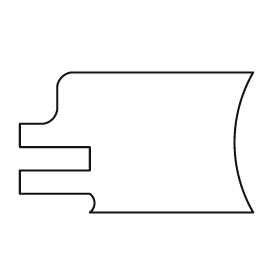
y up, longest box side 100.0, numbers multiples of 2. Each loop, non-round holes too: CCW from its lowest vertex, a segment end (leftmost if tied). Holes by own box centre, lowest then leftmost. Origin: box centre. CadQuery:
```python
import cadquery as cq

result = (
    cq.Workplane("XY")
    .moveTo(-20.0, -30.0)
    .lineTo(50.0, -30.0)
    .threePointArc((42.0, 0.0), (50.0, 30.0))
    .lineTo(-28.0, 30.0)
    .threePointArc((-32.0, 28.0), (-34.0, 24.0))
    .lineTo(-34.0, 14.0)
    .threePointArc((-36.0, 10.0), (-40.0, 8.0))
    .lineTo(-50.0, 8.0)
    .lineTo(-50.0, -2.0)
    .lineTo(-20.0, -2.0)
    .lineTo(-20.0, -12.0)
    .lineTo(-50.0, -12.0)
    .lineTo(-50.0, -22.0)
    .lineTo(-20.0, -22.0)
    .threePointArc((-18.0, -26.0), (-20.0, -30.0))
    .close()
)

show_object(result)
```